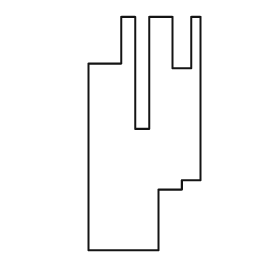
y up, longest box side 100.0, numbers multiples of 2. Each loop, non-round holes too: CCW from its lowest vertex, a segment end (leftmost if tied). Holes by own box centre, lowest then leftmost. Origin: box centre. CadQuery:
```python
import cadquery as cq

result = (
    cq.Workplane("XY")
    .moveTo(-24.0, -50.0)
    .lineTo(6.0, -50.0)
    .lineTo(6.0, -24.0)
    .lineTo(16.0, -24.0)
    .lineTo(16.0, -20.0)
    .lineTo(24.0, -20.0)
    .lineTo(24.0, 50.0)
    .lineTo(20.0, 50.0)
    .lineTo(20.0, 28.0)
    .lineTo(12.0, 28.0)
    .lineTo(12.0, 50.0)
    .lineTo(2.0, 50.0)
    .lineTo(2.0, 2.0)
    .lineTo(-4.0, 2.0)
    .lineTo(-4.0, 50.0)
    .lineTo(-10.0, 50.0)
    .lineTo(-10.0, 30.0)
    .lineTo(-24.0, 30.0)
    .close()
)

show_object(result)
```